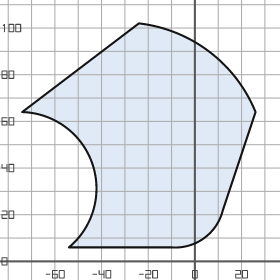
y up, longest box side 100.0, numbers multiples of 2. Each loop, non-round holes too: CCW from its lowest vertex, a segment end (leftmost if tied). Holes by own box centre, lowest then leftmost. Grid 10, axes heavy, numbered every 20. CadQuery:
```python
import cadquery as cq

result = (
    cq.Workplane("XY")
    .moveTo(-54.0, 6.0)
    .lineTo(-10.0, 6.0)
    .threePointArc((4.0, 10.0), (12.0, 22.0))
    .lineTo(26.0, 64.0)
    .threePointArc((6.0, 90.0), (-24.0, 102.0))
    .lineTo(-74.0, 64.0)
    .threePointArc((-44.0, 42.0), (-54.0, 6.0))
    .close()
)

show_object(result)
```